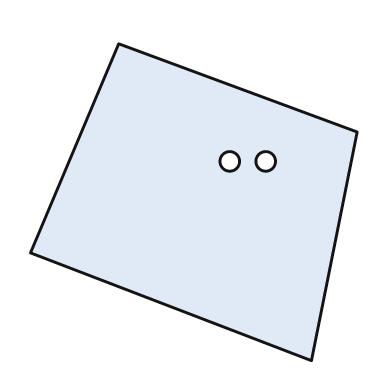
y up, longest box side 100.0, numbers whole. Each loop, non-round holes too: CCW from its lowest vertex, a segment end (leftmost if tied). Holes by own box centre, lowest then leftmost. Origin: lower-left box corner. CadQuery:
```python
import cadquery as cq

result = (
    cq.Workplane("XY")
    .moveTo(86.0, 0.0)
    .lineTo(100.0, 70.0)
    .lineTo(27.0, 97.0)
    .lineTo(0.0, 33.0)
    .close()
    .moveTo(61.0, 61.0)
    .circle(3.0)
    .moveTo(72.0, 61.0)
    .circle(3.0)
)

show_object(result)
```